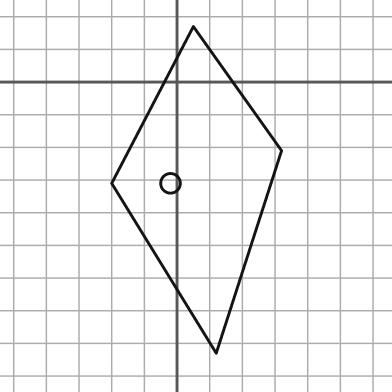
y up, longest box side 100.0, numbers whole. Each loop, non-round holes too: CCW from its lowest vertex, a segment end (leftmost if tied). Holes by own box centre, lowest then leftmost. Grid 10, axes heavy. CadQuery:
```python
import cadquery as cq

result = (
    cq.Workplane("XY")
    .moveTo(12.0, -83.0)
    .lineTo(32.0, -21.0)
    .lineTo(5.0, 17.0)
    .lineTo(-20.0, -31.0)
    .close()
    .moveTo(-2.0, -31.0)
    .circle(3.0)
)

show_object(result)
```